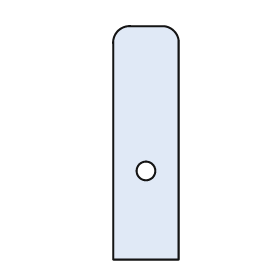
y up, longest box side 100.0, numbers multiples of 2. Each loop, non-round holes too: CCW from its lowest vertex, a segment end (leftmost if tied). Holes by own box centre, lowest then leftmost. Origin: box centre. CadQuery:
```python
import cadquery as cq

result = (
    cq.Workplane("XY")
    .moveTo(-14.0, -50.0)
    .lineTo(14.0, -50.0)
    .lineTo(14.0, 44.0)
    .threePointArc((12.0, 48.0), (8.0, 50.0))
    .lineTo(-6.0, 50.0)
    .threePointArc((-12.0, 48.0), (-14.0, 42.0))
    .close()
    .moveTo(0.0, -12.0)
    .circle(4.0)
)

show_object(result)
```